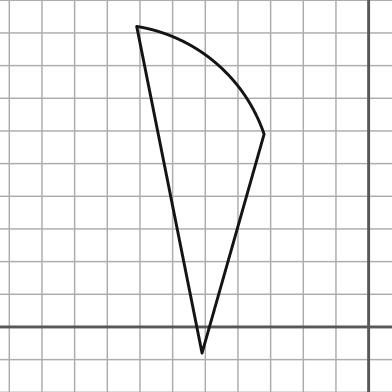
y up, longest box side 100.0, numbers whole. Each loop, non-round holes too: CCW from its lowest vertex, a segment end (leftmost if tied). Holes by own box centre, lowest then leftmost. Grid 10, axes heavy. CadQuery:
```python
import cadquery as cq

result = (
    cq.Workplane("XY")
    .moveTo(-51.0, -8.0)
    .lineTo(-32.0, 59.0)
    .threePointArc((-47.0, 81.0), (-71.0, 92.0))
    .close()
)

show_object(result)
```